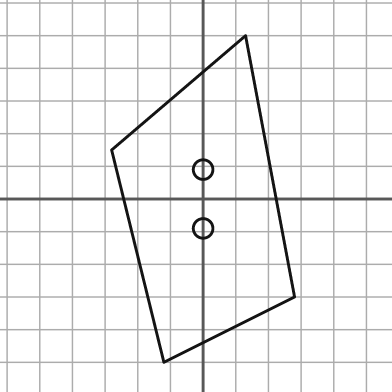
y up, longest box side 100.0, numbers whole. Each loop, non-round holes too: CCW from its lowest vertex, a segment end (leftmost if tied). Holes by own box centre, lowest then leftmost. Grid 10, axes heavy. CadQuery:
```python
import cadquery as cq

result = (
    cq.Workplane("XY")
    .moveTo(-12.0, -50.0)
    .lineTo(28.0, -30.0)
    .lineTo(13.0, 50.0)
    .lineTo(-28.0, 15.0)
    .close()
    .moveTo(0.0, -9.0)
    .circle(3.0)
    .moveTo(0.0, 9.0)
    .circle(3.0)
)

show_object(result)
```